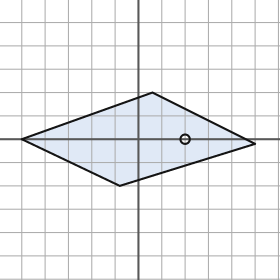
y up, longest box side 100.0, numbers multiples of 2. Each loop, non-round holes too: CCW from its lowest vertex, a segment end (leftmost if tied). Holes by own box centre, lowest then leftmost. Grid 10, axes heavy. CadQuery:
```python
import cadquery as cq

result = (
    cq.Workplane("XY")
    .moveTo(-8.0, -20.0)
    .lineTo(50.0, -2.0)
    .lineTo(6.0, 20.0)
    .lineTo(-50.0, 0.0)
    .close()
    .moveTo(20.0, 0.0)
    .circle(2.0)
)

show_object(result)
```